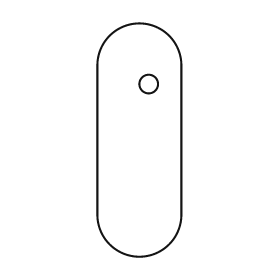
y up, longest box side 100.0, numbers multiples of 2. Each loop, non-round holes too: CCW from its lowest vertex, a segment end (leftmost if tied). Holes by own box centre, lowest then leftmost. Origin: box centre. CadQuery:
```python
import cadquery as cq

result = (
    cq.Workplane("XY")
    .moveTo(-18.0, -32.0)
    .threePointArc((0.0, -50.0), (18.0, -32.0))
    .lineTo(18.0, 32.0)
    .threePointArc((0.0, 50.0), (-18.0, 32.0))
    .close()
    .moveTo(4.0, 24.0)
    .circle(4.0)
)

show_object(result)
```